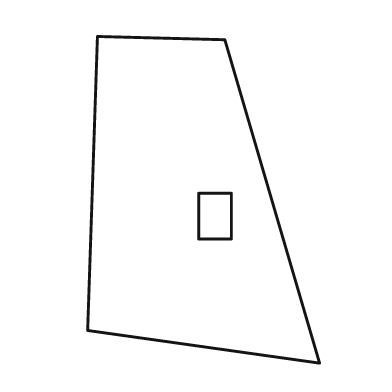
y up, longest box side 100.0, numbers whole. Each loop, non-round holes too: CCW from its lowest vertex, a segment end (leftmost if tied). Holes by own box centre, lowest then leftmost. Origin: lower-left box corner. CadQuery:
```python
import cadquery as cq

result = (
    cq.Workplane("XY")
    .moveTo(71.0, 0.0)
    .lineTo(42.0, 99.0)
    .lineTo(3.0, 100.0)
    .lineTo(0.0, 10.0)
    .close()
    .moveTo(34.0, 38.0)
    .lineTo(44.0, 38.0)
    .lineTo(44.0, 52.0)
    .lineTo(34.0, 52.0)
    .close()
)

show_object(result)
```